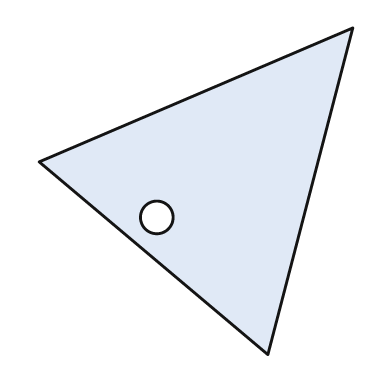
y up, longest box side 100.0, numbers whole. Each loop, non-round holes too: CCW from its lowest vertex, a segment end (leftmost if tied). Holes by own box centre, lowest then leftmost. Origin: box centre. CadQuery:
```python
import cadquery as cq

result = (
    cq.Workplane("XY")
    .moveTo(22.0, -50.0)
    .lineTo(48.0, 50.0)
    .lineTo(-48.0, 9.0)
    .close()
    .moveTo(-12.0, -8.0)
    .circle(5.0)
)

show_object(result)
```